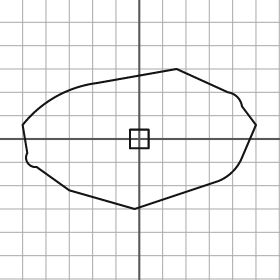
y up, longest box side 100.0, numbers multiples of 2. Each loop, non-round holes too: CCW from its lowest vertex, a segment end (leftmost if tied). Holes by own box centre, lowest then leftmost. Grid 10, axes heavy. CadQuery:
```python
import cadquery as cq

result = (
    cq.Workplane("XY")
    .moveTo(-2.0, -30.0)
    .lineTo(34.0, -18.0)
    .threePointArc((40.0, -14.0), (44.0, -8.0))
    .lineTo(50.0, 6.0)
    .lineTo(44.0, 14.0)
    .threePointArc((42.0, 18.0), (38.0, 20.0))
    .lineTo(16.0, 30.0)
    .lineTo(-18.0, 24.0)
    .threePointArc((-36.0, 18.0), (-50.0, 6.0))
    .lineTo(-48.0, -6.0)
    .threePointArc((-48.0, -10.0), (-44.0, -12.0))
    .lineTo(-30.0, -22.0)
    .close()
    .moveTo(-4.0, -4.0)
    .lineTo(4.0, -4.0)
    .lineTo(4.0, 4.0)
    .lineTo(-4.0, 4.0)
    .close()
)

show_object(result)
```